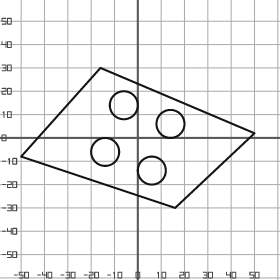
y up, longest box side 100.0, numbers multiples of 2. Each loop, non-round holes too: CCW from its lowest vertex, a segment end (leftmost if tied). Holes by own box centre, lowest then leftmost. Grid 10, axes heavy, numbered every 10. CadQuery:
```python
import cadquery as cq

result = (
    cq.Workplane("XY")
    .moveTo(16.0, -30.0)
    .lineTo(50.0, 2.0)
    .lineTo(-16.0, 30.0)
    .lineTo(-50.0, -8.0)
    .close()
    .moveTo(6.0, -14.0)
    .circle(6.0)
    .moveTo(-14.0, -6.0)
    .circle(6.0)
    .moveTo(14.0, 6.0)
    .circle(6.0)
    .moveTo(-6.0, 14.0)
    .circle(6.0)
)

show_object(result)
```